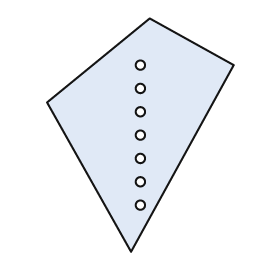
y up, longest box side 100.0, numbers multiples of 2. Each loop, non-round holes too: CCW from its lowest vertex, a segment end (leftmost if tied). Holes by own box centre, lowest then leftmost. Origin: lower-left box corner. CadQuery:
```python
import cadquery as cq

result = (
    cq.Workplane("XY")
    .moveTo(36.0, 0.0)
    .lineTo(80.0, 80.0)
    .lineTo(44.0, 100.0)
    .lineTo(0.0, 64.0)
    .close()
    .moveTo(40.0, 20.0)
    .circle(2.0)
    .moveTo(40.0, 30.0)
    .circle(2.0)
    .moveTo(40.0, 40.0)
    .circle(2.0)
    .moveTo(40.0, 50.0)
    .circle(2.0)
    .moveTo(40.0, 60.0)
    .circle(2.0)
    .moveTo(40.0, 70.0)
    .circle(2.0)
    .moveTo(40.0, 80.0)
    .circle(2.0)
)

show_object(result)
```